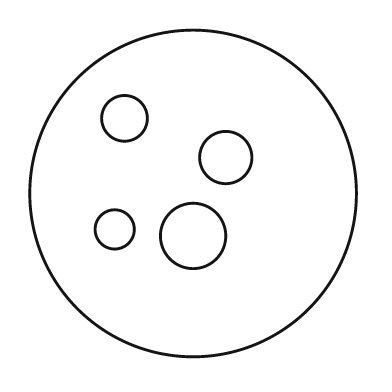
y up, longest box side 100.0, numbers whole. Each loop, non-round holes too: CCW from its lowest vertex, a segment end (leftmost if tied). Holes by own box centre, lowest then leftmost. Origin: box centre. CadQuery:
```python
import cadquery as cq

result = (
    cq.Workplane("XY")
    .moveTo(0.0, 0.0)
    .circle(50.0)
    .moveTo(0.0, -13.0)
    .circle(10.0)
    .moveTo(-24.0, -11.0)
    .circle(6.0)
    .moveTo(10.0, 11.0)
    .circle(8.0)
    .moveTo(-21.0, 23.0)
    .circle(7.0)
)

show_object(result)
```